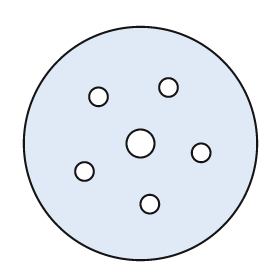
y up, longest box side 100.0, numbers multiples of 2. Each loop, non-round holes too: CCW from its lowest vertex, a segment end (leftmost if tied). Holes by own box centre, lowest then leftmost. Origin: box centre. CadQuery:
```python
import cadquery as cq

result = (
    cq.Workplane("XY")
    .moveTo(0.0, 0.0)
    .circle(50.0)
    .moveTo(4.0, -26.0)
    .circle(4.0)
    .moveTo(-24.0, -12.0)
    .circle(4.0)
    .moveTo(26.0, -4.0)
    .circle(4.0)
    .moveTo(0.0, 0.0)
    .circle(6.0)
    .moveTo(-18.0, 20.0)
    .circle(4.0)
    .moveTo(12.0, 24.0)
    .circle(4.0)
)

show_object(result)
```